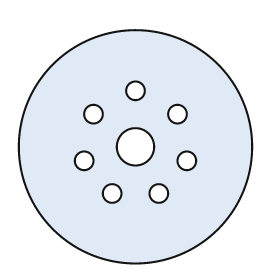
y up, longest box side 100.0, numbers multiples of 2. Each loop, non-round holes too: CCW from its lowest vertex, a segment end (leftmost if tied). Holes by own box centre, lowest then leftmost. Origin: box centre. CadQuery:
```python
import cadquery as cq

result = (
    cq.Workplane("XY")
    .moveTo(0.0, 0.0)
    .circle(50.0)
    .moveTo(-10.0, -20.0)
    .circle(4.0)
    .moveTo(10.0, -20.0)
    .circle(4.0)
    .moveTo(-22.0, -6.0)
    .circle(4.0)
    .moveTo(22.0, -6.0)
    .circle(4.0)
    .moveTo(0.0, 0.0)
    .circle(8.0)
    .moveTo(-18.0, 14.0)
    .circle(4.0)
    .moveTo(18.0, 14.0)
    .circle(4.0)
    .moveTo(0.0, 24.0)
    .circle(4.0)
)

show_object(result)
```